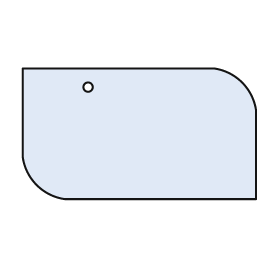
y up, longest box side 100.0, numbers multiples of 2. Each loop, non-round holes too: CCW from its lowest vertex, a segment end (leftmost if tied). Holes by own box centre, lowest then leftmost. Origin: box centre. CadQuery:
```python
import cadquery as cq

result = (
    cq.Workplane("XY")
    .moveTo(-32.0, -28.0)
    .lineTo(50.0, -28.0)
    .lineTo(50.0, 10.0)
    .threePointArc((44.0, 22.0), (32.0, 28.0))
    .lineTo(-50.0, 28.0)
    .lineTo(-50.0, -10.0)
    .threePointArc((-44.0, -22.0), (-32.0, -28.0))
    .close()
    .moveTo(-22.0, 20.0)
    .circle(2.0)
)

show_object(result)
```